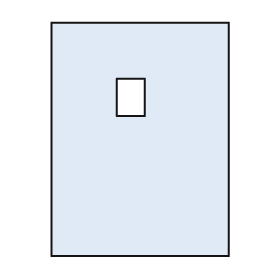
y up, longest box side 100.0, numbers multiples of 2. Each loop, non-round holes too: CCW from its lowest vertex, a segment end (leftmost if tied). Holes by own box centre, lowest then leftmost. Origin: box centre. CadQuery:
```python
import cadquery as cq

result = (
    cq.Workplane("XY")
    .moveTo(-38.0, -50.0)
    .lineTo(38.0, -50.0)
    .lineTo(38.0, 50.0)
    .lineTo(-38.0, 50.0)
    .close()
    .moveTo(-10.0, 10.0)
    .lineTo(2.0, 10.0)
    .lineTo(2.0, 26.0)
    .lineTo(-10.0, 26.0)
    .close()
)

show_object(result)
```